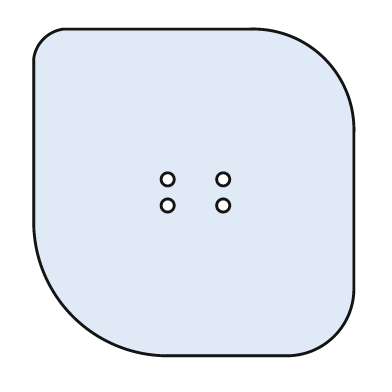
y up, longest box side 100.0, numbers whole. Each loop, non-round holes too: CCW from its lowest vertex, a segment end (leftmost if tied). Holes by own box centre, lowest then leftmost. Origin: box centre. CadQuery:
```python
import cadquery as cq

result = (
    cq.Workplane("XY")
    .moveTo(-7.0, -50.0)
    .lineTo(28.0, -50.0)
    .threePointArc((43.0, -44.0), (49.0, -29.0))
    .lineTo(49.0, 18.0)
    .threePointArc((40.0, 41.0), (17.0, 50.0))
    .lineTo(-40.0, 50.0)
    .threePointArc((-46.0, 47.0), (-49.0, 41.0))
    .lineTo(-49.0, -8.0)
    .threePointArc((-37.0, -38.0), (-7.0, -50.0))
    .close()
    .moveTo(-8.0, -4.0)
    .circle(2.0)
    .moveTo(9.0, -4.0)
    .circle(2.0)
    .moveTo(-8.0, 4.0)
    .circle(2.0)
    .moveTo(9.0, 4.0)
    .circle(2.0)
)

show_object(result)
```